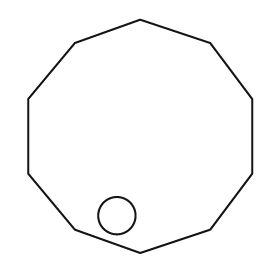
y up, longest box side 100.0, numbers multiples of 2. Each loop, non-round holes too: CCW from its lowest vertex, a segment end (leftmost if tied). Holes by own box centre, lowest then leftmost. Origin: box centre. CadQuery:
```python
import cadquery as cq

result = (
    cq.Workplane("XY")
    .moveTo(0.0, -50.0)
    .lineTo(30.0, -40.0)
    .lineTo(48.0, -16.0)
    .lineTo(48.0, 16.0)
    .lineTo(30.0, 40.0)
    .lineTo(0.0, 50.0)
    .lineTo(-28.0, 40.0)
    .lineTo(-48.0, 16.0)
    .lineTo(-48.0, -16.0)
    .lineTo(-28.0, -40.0)
    .close()
    .moveTo(-10.0, -34.0)
    .circle(8.0)
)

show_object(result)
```